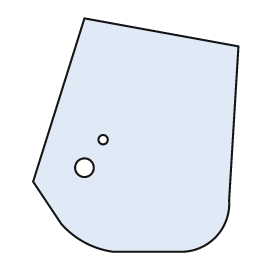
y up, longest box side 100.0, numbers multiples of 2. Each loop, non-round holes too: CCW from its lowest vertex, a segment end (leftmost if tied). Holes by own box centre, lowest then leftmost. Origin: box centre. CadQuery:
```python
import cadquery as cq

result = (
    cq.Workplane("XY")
    .moveTo(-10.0, -50.0)
    .lineTo(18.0, -50.0)
    .threePointArc((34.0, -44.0), (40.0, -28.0))
    .lineTo(44.0, 38.0)
    .lineTo(-22.0, 50.0)
    .lineTo(-44.0, -20.0)
    .lineTo(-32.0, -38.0)
    .threePointArc((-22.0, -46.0), (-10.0, -50.0))
    .close()
    .moveTo(-22.0, -14.0)
    .circle(4.0)
    .moveTo(-14.0, -2.0)
    .circle(2.0)
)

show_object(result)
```